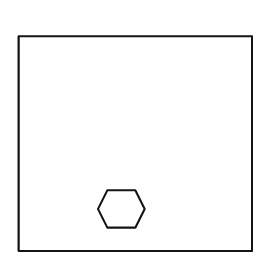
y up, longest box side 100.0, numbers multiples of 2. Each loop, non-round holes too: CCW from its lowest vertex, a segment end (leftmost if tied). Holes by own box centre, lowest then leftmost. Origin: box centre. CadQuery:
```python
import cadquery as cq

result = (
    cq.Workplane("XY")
    .moveTo(-50.0, -46.0)
    .lineTo(50.0, -46.0)
    .lineTo(50.0, 46.0)
    .lineTo(-50.0, 46.0)
    .close()
    .moveTo(-12.0, -36.0)
    .lineTo(0.0, -36.0)
    .lineTo(4.0, -28.0)
    .lineTo(0.0, -20.0)
    .lineTo(-12.0, -20.0)
    .lineTo(-16.0, -28.0)
    .close()
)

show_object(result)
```